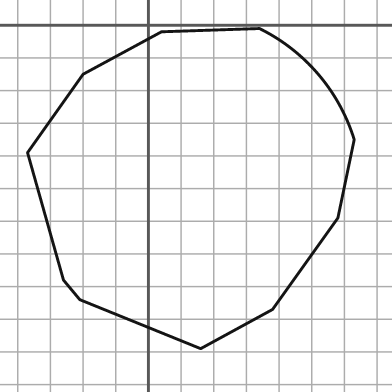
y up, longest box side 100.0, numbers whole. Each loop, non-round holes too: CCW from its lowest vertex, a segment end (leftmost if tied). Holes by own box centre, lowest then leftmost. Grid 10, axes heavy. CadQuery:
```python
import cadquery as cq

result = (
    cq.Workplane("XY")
    .moveTo(16.0, -99.0)
    .lineTo(38.0, -87.0)
    .lineTo(58.0, -59.0)
    .lineTo(63.0, -35.0)
    .threePointArc((52.0, -15.0), (34.0, -1.0))
    .lineTo(4.0, -2.0)
    .lineTo(-20.0, -15.0)
    .lineTo(-37.0, -39.0)
    .lineTo(-26.0, -78.0)
    .lineTo(-21.0, -84.0)
    .close()
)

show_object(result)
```